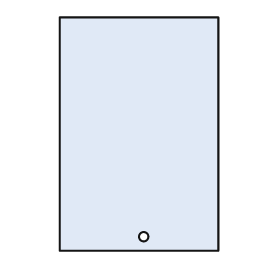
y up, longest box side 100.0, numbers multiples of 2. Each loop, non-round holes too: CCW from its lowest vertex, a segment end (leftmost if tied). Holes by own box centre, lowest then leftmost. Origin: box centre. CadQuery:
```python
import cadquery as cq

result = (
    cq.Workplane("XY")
    .moveTo(-34.0, -50.0)
    .lineTo(34.0, -50.0)
    .lineTo(34.0, 50.0)
    .lineTo(-34.0, 50.0)
    .close()
    .moveTo(2.0, -44.0)
    .circle(2.0)
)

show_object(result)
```